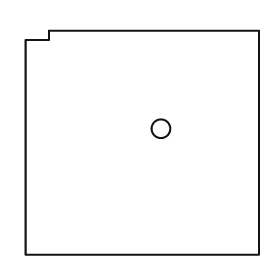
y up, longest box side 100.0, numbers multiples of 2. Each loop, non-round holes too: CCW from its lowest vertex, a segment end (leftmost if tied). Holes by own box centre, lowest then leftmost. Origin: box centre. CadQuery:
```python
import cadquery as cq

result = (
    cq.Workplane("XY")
    .moveTo(-50.0, -48.0)
    .lineTo(50.0, -48.0)
    .lineTo(50.0, 48.0)
    .lineTo(-40.0, 48.0)
    .lineTo(-40.0, 44.0)
    .lineTo(-50.0, 44.0)
    .close()
    .moveTo(8.0, 6.0)
    .circle(4.0)
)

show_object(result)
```